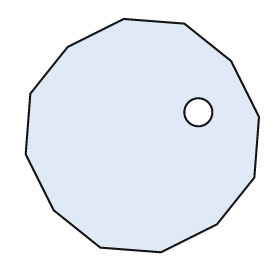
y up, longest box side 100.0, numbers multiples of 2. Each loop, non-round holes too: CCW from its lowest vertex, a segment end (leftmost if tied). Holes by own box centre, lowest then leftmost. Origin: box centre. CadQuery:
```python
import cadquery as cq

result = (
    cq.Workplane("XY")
    .moveTo(8.0, -50.0)
    .lineTo(32.0, -38.0)
    .lineTo(48.0, -18.0)
    .lineTo(50.0, 8.0)
    .lineTo(38.0, 32.0)
    .lineTo(18.0, 48.0)
    .lineTo(-8.0, 50.0)
    .lineTo(-32.0, 38.0)
    .lineTo(-48.0, 18.0)
    .lineTo(-50.0, -8.0)
    .lineTo(-38.0, -32.0)
    .lineTo(-18.0, -48.0)
    .close()
    .moveTo(24.0, 10.0)
    .circle(6.0)
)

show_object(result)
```